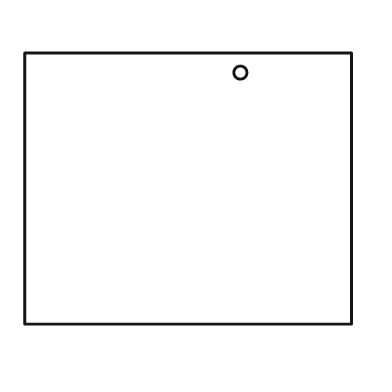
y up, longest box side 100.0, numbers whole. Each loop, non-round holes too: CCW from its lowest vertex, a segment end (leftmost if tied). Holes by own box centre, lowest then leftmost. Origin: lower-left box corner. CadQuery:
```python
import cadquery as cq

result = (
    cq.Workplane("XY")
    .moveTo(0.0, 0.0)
    .lineTo(100.0, 0.0)
    .lineTo(100.0, 83.0)
    .lineTo(0.0, 83.0)
    .close()
    .moveTo(66.0, 77.0)
    .circle(2.0)
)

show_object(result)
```